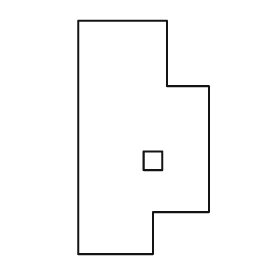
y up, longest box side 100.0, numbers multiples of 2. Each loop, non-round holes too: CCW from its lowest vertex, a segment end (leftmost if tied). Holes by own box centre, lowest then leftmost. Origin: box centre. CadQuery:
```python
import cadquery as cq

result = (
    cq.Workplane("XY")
    .moveTo(-28.0, -50.0)
    .lineTo(4.0, -50.0)
    .lineTo(4.0, -32.0)
    .lineTo(28.0, -32.0)
    .lineTo(28.0, 22.0)
    .lineTo(10.0, 22.0)
    .lineTo(10.0, 50.0)
    .lineTo(-28.0, 50.0)
    .close()
    .moveTo(0.0, -14.0)
    .lineTo(8.0, -14.0)
    .lineTo(8.0, -6.0)
    .lineTo(0.0, -6.0)
    .close()
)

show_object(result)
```